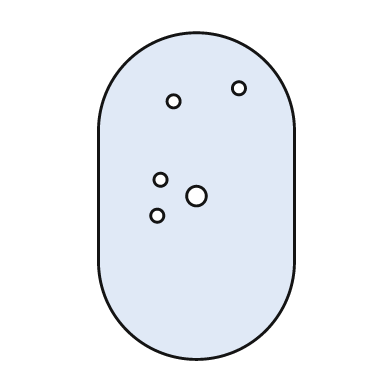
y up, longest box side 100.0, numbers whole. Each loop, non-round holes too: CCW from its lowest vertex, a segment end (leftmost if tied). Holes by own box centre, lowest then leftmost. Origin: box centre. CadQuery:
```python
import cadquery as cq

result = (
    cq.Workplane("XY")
    .moveTo(-30.0, -20.0)
    .threePointArc((0.0, -50.0), (30.0, -20.0))
    .lineTo(30.0, 20.0)
    .threePointArc((0.0, 50.0), (-30.0, 20.0))
    .close()
    .moveTo(-12.0, -6.0)
    .circle(2.0)
    .moveTo(0.0, 0.0)
    .circle(3.0)
    .moveTo(-11.0, 5.0)
    .circle(2.0)
    .moveTo(-7.0, 29.0)
    .circle(2.0)
    .moveTo(13.0, 33.0)
    .circle(2.0)
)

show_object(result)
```